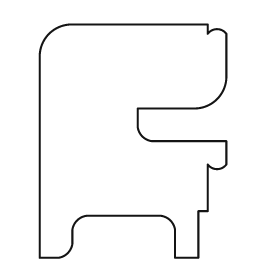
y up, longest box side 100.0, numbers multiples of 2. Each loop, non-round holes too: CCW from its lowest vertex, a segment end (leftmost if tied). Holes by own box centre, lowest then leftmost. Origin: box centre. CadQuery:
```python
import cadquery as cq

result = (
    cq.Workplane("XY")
    .moveTo(-40.0, -50.0)
    .lineTo(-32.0, -50.0)
    .threePointArc((-28.0, -48.0), (-26.0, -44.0))
    .lineTo(-26.0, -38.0)
    .threePointArc((-24.0, -34.0), (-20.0, -32.0))
    .lineTo(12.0, -32.0)
    .threePointArc((16.0, -34.0), (18.0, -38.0))
    .lineTo(18.0, -50.0)
    .lineTo(28.0, -50.0)
    .lineTo(28.0, -30.0)
    .lineTo(32.0, -30.0)
    .lineTo(32.0, -10.0)
    .threePointArc((36.0, -12.0), (40.0, -10.0))
    .lineTo(40.0, 0.0)
    .lineTo(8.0, 0.0)
    .threePointArc((4.0, 2.0), (2.0, 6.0))
    .lineTo(2.0, 14.0)
    .lineTo(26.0, 14.0)
    .threePointArc((36.0, 18.0), (40.0, 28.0))
    .lineTo(40.0, 46.0)
    .threePointArc((36.0, 48.0), (32.0, 46.0))
    .lineTo(32.0, 50.0)
    .lineTo(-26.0, 50.0)
    .threePointArc((-36.0, 46.0), (-40.0, 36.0))
    .close()
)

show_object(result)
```